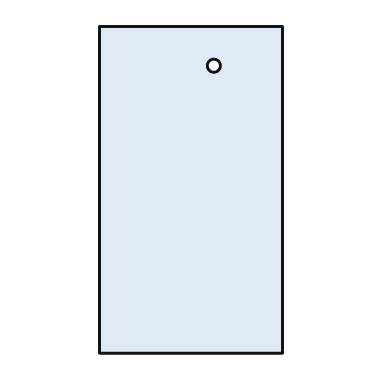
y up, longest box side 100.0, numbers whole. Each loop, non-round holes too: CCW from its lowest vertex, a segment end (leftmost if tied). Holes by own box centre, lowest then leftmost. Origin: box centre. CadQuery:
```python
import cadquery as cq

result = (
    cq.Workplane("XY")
    .moveTo(-28.0, -50.0)
    .lineTo(28.0, -50.0)
    .lineTo(28.0, 50.0)
    .lineTo(-28.0, 50.0)
    .close()
    .moveTo(7.0, 38.0)
    .circle(2.0)
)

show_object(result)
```